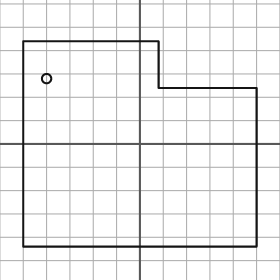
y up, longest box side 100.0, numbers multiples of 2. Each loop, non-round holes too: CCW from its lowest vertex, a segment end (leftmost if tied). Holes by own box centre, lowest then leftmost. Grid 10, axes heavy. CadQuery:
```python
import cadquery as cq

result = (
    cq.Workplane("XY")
    .moveTo(-50.0, -44.0)
    .lineTo(50.0, -44.0)
    .lineTo(50.0, 24.0)
    .lineTo(8.0, 24.0)
    .lineTo(8.0, 44.0)
    .lineTo(-50.0, 44.0)
    .close()
    .moveTo(-40.0, 28.0)
    .circle(2.0)
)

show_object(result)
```